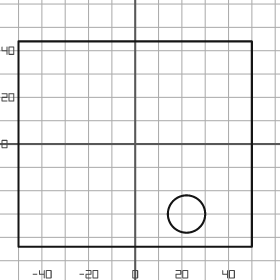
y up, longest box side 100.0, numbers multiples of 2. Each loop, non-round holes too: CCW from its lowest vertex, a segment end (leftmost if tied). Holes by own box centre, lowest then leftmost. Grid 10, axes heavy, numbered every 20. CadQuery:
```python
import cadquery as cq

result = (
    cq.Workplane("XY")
    .moveTo(-50.0, -44.0)
    .lineTo(50.0, -44.0)
    .lineTo(50.0, 44.0)
    .lineTo(-50.0, 44.0)
    .close()
    .moveTo(22.0, -30.0)
    .circle(8.0)
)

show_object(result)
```